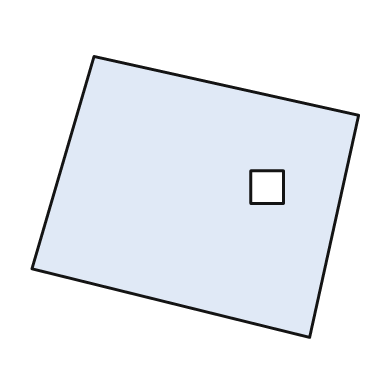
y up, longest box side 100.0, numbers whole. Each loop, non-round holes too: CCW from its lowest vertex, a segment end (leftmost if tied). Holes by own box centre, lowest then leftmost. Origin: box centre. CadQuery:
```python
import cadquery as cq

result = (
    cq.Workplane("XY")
    .moveTo(35.0, -43.0)
    .lineTo(50.0, 25.0)
    .lineTo(-31.0, 43.0)
    .lineTo(-50.0, -22.0)
    .close()
    .moveTo(17.0, -2.0)
    .lineTo(27.0, -2.0)
    .lineTo(27.0, 8.0)
    .lineTo(17.0, 8.0)
    .close()
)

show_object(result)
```